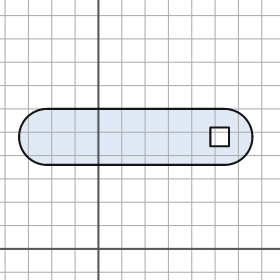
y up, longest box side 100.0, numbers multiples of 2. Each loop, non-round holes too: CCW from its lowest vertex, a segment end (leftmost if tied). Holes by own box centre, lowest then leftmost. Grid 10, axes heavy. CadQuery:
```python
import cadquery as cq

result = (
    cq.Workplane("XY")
    .moveTo(-22.0, 36.0)
    .lineTo(54.0, 36.0)
    .threePointArc((66.0, 48.0), (54.0, 60.0))
    .lineTo(-22.0, 60.0)
    .threePointArc((-34.0, 48.0), (-22.0, 36.0))
    .close()
    .moveTo(48.0, 44.0)
    .lineTo(56.0, 44.0)
    .lineTo(56.0, 52.0)
    .lineTo(48.0, 52.0)
    .close()
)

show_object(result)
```